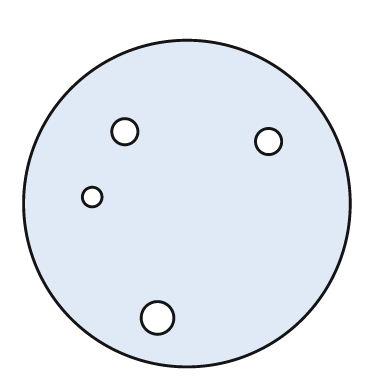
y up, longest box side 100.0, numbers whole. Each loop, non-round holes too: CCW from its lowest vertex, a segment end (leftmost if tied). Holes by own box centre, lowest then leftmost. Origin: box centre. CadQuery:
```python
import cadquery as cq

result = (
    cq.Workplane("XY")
    .moveTo(0.0, 0.0)
    .circle(50.0)
    .moveTo(-9.0, -35.0)
    .circle(5.0)
    .moveTo(-29.0, 2.0)
    .circle(3.0)
    .moveTo(25.0, 19.0)
    .circle(4.0)
    .moveTo(-19.0, 22.0)
    .circle(4.0)
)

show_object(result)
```